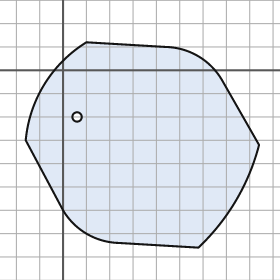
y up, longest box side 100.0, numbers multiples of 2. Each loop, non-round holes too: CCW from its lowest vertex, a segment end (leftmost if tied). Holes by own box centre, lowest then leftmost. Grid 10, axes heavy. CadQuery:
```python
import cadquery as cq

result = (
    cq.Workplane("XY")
    .moveTo(58.0, -76.0)
    .threePointArc((74.0, -56.0), (84.0, -32.0))
    .lineTo(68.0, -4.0)
    .threePointArc((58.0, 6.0), (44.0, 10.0))
    .lineTo(10.0, 12.0)
    .threePointArc((-8.0, -6.0), (-16.0, -30.0))
    .lineTo(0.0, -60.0)
    .threePointArc((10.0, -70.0), (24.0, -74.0))
    .close()
    .moveTo(6.0, -20.0)
    .circle(2.0)
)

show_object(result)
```